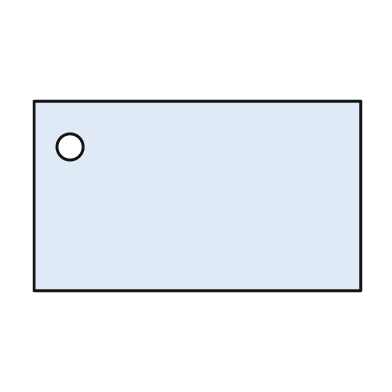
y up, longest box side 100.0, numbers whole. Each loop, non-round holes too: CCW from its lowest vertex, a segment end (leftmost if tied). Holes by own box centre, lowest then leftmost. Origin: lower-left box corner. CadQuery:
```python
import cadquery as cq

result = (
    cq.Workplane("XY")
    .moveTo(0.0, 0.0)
    .lineTo(100.0, 0.0)
    .lineTo(100.0, 58.0)
    .lineTo(0.0, 58.0)
    .close()
    .moveTo(11.0, 44.0)
    .circle(4.0)
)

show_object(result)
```